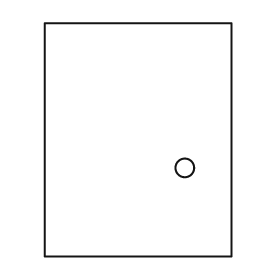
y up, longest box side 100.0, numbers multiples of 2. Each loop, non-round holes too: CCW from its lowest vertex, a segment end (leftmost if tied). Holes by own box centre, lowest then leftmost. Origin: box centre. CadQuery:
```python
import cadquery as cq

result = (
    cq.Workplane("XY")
    .moveTo(-40.0, -50.0)
    .lineTo(40.0, -50.0)
    .lineTo(40.0, 50.0)
    .lineTo(-40.0, 50.0)
    .close()
    .moveTo(20.0, -12.0)
    .circle(4.0)
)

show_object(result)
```